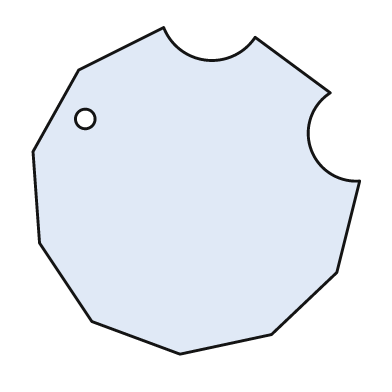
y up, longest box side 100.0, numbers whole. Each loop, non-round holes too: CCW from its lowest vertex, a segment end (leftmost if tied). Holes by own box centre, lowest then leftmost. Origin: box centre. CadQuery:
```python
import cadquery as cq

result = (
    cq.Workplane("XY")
    .moveTo(-5.0, -50.0)
    .lineTo(23.0, -44.0)
    .lineTo(43.0, -25.0)
    .lineTo(50.0, 3.0)
    .threePointArc((35.0, 13.0), (41.0, 30.0))
    .lineTo(18.0, 47.0)
    .threePointArc((3.0, 40.0), (-10.0, 50.0))
    .lineTo(-36.0, 37.0)
    .lineTo(-50.0, 12.0)
    .lineTo(-48.0, -16.0)
    .lineTo(-32.0, -40.0)
    .close()
    .moveTo(-34.0, 22.0)
    .circle(3.0)
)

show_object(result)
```